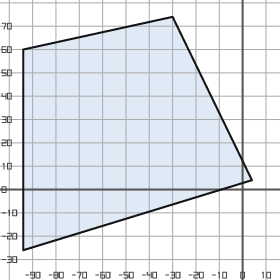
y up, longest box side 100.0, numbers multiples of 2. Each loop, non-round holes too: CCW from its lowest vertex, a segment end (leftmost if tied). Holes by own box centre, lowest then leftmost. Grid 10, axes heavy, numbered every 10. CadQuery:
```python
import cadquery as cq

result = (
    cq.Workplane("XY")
    .moveTo(-94.0, -26.0)
    .lineTo(4.0, 4.0)
    .lineTo(-30.0, 74.0)
    .lineTo(-94.0, 60.0)
    .close()
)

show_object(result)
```